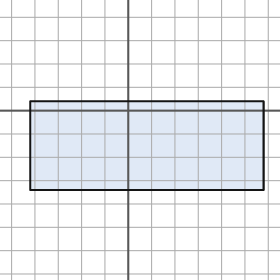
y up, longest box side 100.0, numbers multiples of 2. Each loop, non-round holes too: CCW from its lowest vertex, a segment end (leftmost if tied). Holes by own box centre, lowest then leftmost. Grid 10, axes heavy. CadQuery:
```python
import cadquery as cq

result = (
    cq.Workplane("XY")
    .moveTo(-42.0, -34.0)
    .lineTo(58.0, -34.0)
    .lineTo(58.0, 4.0)
    .lineTo(-42.0, 4.0)
    .close()
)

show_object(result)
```